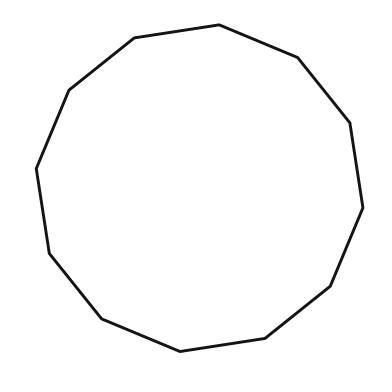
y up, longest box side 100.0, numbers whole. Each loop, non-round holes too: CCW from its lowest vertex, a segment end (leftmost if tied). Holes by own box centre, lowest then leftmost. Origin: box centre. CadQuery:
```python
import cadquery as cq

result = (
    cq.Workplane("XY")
    .moveTo(-6.0, -50.0)
    .lineTo(20.0, -46.0)
    .lineTo(40.0, -30.0)
    .lineTo(50.0, -6.0)
    .lineTo(46.0, 20.0)
    .lineTo(30.0, 40.0)
    .lineTo(6.0, 50.0)
    .lineTo(-20.0, 46.0)
    .lineTo(-40.0, 30.0)
    .lineTo(-50.0, 6.0)
    .lineTo(-46.0, -20.0)
    .lineTo(-30.0, -40.0)
    .close()
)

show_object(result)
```